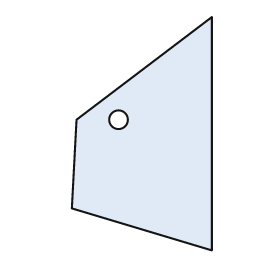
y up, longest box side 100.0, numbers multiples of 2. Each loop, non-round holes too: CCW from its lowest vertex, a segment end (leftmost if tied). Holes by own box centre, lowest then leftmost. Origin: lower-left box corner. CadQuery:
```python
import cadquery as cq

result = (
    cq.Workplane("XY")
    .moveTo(60.0, 0.0)
    .lineTo(60.0, 100.0)
    .lineTo(2.0, 56.0)
    .lineTo(0.0, 18.0)
    .close()
    .moveTo(20.0, 56.0)
    .circle(4.0)
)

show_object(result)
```